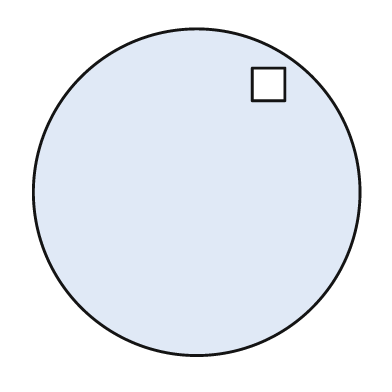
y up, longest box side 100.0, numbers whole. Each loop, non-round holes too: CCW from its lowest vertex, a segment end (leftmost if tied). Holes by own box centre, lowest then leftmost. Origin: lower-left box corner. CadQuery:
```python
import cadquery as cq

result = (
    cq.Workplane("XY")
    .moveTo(50.0, 50.0)
    .circle(50.0)
    .moveTo(67.0, 78.0)
    .lineTo(77.0, 78.0)
    .lineTo(77.0, 88.0)
    .lineTo(67.0, 88.0)
    .close()
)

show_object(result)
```